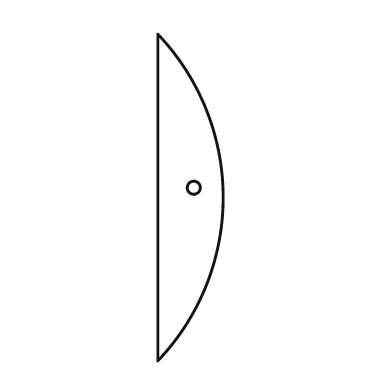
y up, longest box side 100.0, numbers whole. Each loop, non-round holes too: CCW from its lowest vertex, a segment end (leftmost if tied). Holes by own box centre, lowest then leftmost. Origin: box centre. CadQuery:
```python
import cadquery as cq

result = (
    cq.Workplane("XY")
    .moveTo(-10.0, -50.0)
    .threePointArc((10.0, 0.0), (-10.0, 50.0))
    .close()
    .moveTo(1.0, 3.0)
    .circle(2.0)
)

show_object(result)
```